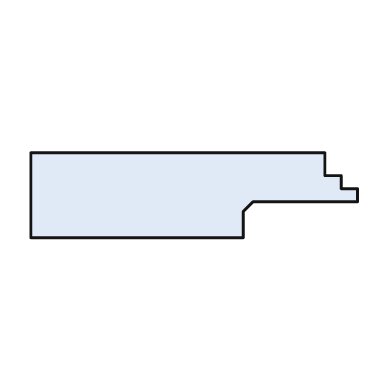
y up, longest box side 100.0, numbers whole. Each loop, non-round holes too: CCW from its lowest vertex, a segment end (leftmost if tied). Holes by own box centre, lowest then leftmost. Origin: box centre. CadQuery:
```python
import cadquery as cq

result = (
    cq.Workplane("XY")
    .moveTo(-50.0, -13.0)
    .lineTo(15.0, -13.0)
    .lineTo(15.0, -5.0)
    .lineTo(18.0, -2.0)
    .lineTo(50.0, -2.0)
    .lineTo(50.0, 2.0)
    .lineTo(45.0, 2.0)
    .lineTo(45.0, 6.0)
    .lineTo(40.0, 6.0)
    .lineTo(40.0, 13.0)
    .lineTo(-50.0, 13.0)
    .close()
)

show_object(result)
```